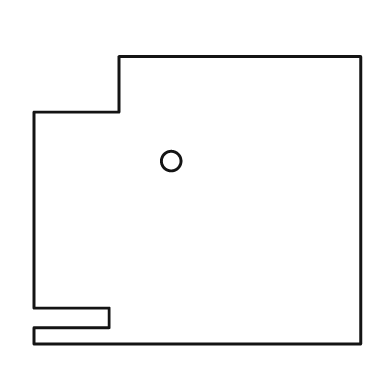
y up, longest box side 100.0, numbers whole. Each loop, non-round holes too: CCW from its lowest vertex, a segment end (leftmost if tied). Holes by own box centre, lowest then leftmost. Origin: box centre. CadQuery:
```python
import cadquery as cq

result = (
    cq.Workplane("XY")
    .moveTo(-50.0, -44.0)
    .lineTo(50.0, -44.0)
    .lineTo(50.0, 44.0)
    .lineTo(-24.0, 44.0)
    .lineTo(-24.0, 27.0)
    .lineTo(-50.0, 27.0)
    .lineTo(-50.0, -33.0)
    .lineTo(-27.0, -33.0)
    .lineTo(-27.0, -39.0)
    .lineTo(-50.0, -39.0)
    .close()
    .moveTo(-8.0, 12.0)
    .circle(3.0)
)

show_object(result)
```